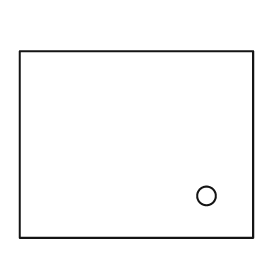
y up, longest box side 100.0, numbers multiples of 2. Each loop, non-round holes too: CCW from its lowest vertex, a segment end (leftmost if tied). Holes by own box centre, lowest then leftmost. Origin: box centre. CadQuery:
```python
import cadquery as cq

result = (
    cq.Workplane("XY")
    .moveTo(-50.0, -40.0)
    .lineTo(50.0, -40.0)
    .lineTo(50.0, 40.0)
    .lineTo(-50.0, 40.0)
    .close()
    .moveTo(30.0, -22.0)
    .circle(4.0)
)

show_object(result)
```